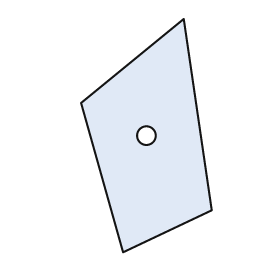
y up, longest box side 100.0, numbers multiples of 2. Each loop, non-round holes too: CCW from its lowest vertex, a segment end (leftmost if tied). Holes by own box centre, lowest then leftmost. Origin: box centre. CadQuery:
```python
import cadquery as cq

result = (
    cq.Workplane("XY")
    .moveTo(-10.0, -50.0)
    .lineTo(28.0, -32.0)
    .lineTo(16.0, 50.0)
    .lineTo(-28.0, 14.0)
    .close()
    .moveTo(0.0, 0.0)
    .circle(4.0)
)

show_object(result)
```